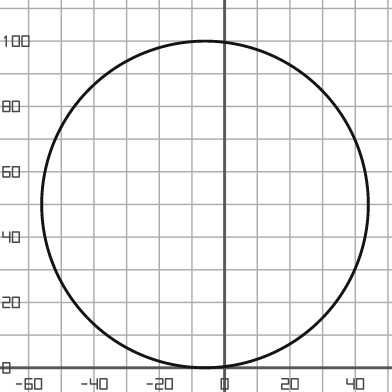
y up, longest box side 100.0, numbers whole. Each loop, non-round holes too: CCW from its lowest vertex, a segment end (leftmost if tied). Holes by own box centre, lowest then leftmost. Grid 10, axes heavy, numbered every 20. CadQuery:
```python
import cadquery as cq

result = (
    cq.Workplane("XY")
    .moveTo(-6.0, 50.0)
    .circle(50.0)
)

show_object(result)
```